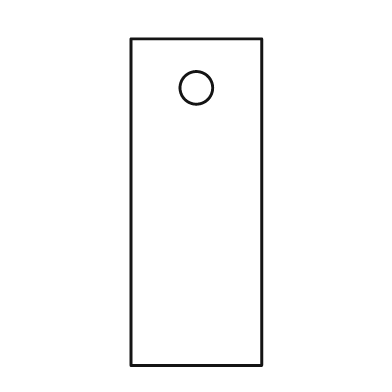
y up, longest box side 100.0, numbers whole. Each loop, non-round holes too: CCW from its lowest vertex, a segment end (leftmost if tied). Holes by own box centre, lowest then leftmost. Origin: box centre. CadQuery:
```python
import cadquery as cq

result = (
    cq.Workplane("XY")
    .moveTo(-20.0, -50.0)
    .lineTo(20.0, -50.0)
    .lineTo(20.0, 50.0)
    .lineTo(-20.0, 50.0)
    .close()
    .moveTo(0.0, 35.0)
    .circle(5.0)
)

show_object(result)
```